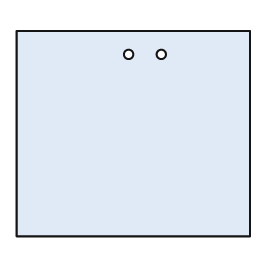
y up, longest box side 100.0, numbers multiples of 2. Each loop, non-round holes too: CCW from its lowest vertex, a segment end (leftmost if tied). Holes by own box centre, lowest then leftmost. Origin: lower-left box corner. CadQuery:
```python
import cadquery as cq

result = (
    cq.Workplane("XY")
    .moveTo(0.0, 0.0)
    .lineTo(100.0, 0.0)
    .lineTo(100.0, 88.0)
    .lineTo(0.0, 88.0)
    .close()
    .moveTo(48.0, 78.0)
    .circle(2.0)
    .moveTo(62.0, 78.0)
    .circle(2.0)
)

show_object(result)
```